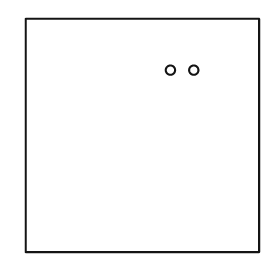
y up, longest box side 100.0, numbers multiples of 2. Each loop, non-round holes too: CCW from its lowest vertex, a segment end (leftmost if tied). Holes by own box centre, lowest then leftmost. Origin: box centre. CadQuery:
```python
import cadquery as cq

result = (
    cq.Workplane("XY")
    .moveTo(-50.0, -50.0)
    .lineTo(50.0, -50.0)
    .lineTo(50.0, 50.0)
    .lineTo(-50.0, 50.0)
    .close()
    .moveTo(12.0, 28.0)
    .circle(2.0)
    .moveTo(22.0, 28.0)
    .circle(2.0)
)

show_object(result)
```